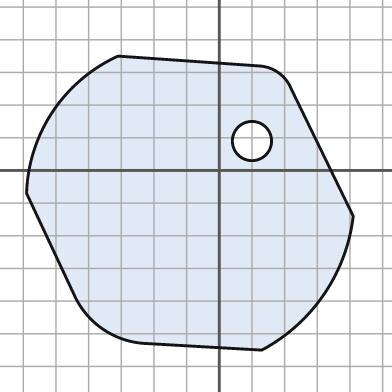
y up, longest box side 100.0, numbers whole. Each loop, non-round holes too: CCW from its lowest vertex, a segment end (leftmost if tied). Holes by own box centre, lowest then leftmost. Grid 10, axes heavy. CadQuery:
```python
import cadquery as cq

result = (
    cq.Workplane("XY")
    .moveTo(13.0, -55.0)
    .threePointArc((32.0, -38.0), (41.0, -14.0))
    .lineTo(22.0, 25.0)
    .threePointArc((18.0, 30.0), (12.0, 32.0))
    .lineTo(-31.0, 35.0)
    .threePointArc((-51.0, 18.0), (-59.0, -7.0))
    .lineTo(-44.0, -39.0)
    .threePointArc((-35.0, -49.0), (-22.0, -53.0))
    .close()
    .moveTo(10.0, 9.0)
    .circle(6.0)
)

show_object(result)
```